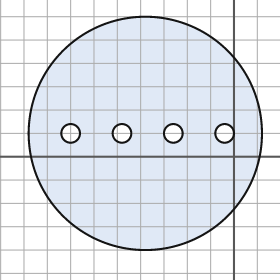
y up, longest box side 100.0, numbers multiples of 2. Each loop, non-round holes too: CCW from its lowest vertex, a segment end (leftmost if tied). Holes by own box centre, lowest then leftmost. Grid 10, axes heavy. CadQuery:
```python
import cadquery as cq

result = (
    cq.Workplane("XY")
    .moveTo(-38.0, 10.0)
    .circle(50.0)
    .moveTo(-70.0, 10.0)
    .circle(4.0)
    .moveTo(-48.0, 10.0)
    .circle(4.0)
    .moveTo(-26.0, 10.0)
    .circle(4.0)
    .moveTo(-4.0, 10.0)
    .circle(4.0)
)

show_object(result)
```